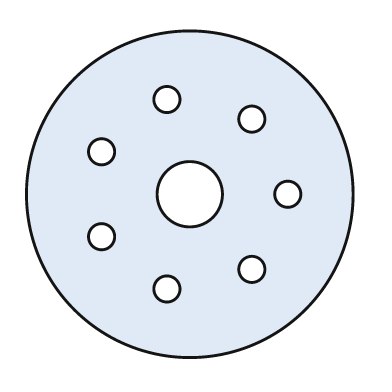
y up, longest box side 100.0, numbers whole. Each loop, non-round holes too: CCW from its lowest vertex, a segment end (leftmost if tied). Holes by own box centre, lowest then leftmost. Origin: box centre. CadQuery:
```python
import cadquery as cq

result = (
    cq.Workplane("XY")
    .moveTo(0.0, 0.0)
    .circle(50.0)
    .moveTo(-7.0, -29.0)
    .circle(4.0)
    .moveTo(19.0, -23.0)
    .circle(4.0)
    .moveTo(-27.0, -13.0)
    .circle(4.0)
    .moveTo(0.0, 0.0)
    .circle(10.0)
    .moveTo(30.0, 0.0)
    .circle(4.0)
    .moveTo(-27.0, 13.0)
    .circle(4.0)
    .moveTo(19.0, 23.0)
    .circle(4.0)
    .moveTo(-7.0, 29.0)
    .circle(4.0)
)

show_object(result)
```